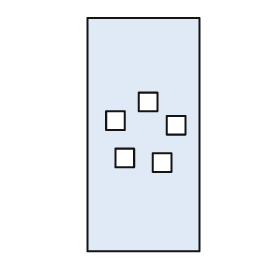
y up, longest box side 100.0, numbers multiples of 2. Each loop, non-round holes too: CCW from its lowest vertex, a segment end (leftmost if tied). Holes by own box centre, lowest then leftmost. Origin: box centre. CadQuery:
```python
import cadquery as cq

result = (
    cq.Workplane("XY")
    .moveTo(-24.0, -50.0)
    .lineTo(24.0, -50.0)
    .lineTo(24.0, 50.0)
    .lineTo(-24.0, 50.0)
    .close()
    .moveTo(4.0, -16.0)
    .lineTo(12.0, -16.0)
    .lineTo(12.0, -8.0)
    .lineTo(4.0, -8.0)
    .close()
    .moveTo(-12.0, -14.0)
    .lineTo(-4.0, -14.0)
    .lineTo(-4.0, -6.0)
    .lineTo(-12.0, -6.0)
    .close()
    .moveTo(10.0, 0.0)
    .lineTo(18.0, 0.0)
    .lineTo(18.0, 8.0)
    .lineTo(10.0, 8.0)
    .close()
    .moveTo(-16.0, 2.0)
    .lineTo(-8.0, 2.0)
    .lineTo(-8.0, 10.0)
    .lineTo(-16.0, 10.0)
    .close()
    .moveTo(-2.0, 10.0)
    .lineTo(6.0, 10.0)
    .lineTo(6.0, 18.0)
    .lineTo(-2.0, 18.0)
    .close()
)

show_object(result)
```